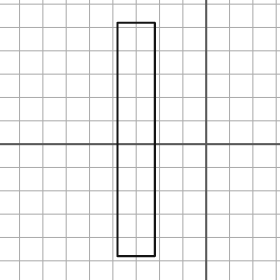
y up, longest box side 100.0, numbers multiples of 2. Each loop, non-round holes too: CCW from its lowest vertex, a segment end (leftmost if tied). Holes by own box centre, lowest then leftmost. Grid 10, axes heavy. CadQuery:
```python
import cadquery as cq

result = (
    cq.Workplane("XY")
    .moveTo(-38.0, -48.0)
    .lineTo(-22.0, -48.0)
    .lineTo(-22.0, 52.0)
    .lineTo(-38.0, 52.0)
    .close()
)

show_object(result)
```